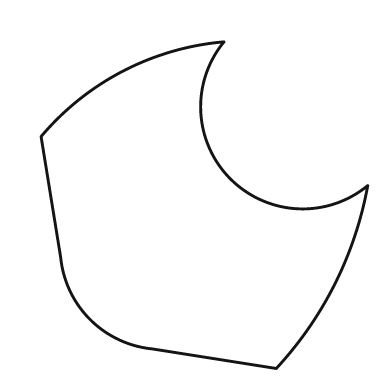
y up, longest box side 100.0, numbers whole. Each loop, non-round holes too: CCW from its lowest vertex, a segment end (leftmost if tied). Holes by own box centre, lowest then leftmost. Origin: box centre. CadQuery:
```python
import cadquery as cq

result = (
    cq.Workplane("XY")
    .moveTo(22.0, -50.0)
    .threePointArc((40.0, -24.0), (50.0, 6.0))
    .threePointArc((8.0, 8.0), (6.0, 50.0))
    .threePointArc((-25.0, 41.0), (-50.0, 21.0))
    .lineTo(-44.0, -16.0)
    .threePointArc((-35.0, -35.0), (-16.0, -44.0))
    .close()
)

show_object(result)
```